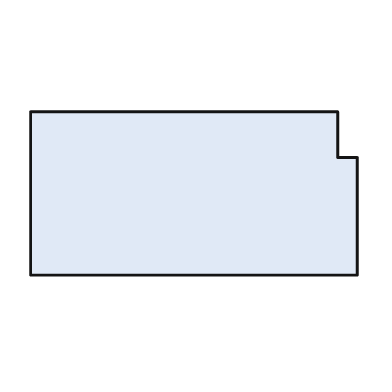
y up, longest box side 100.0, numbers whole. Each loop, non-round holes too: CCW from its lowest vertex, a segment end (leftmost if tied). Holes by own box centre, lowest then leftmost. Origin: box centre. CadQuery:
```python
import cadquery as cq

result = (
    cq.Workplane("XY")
    .moveTo(-50.0, -25.0)
    .lineTo(50.0, -25.0)
    .lineTo(50.0, 11.0)
    .lineTo(44.0, 11.0)
    .lineTo(44.0, 25.0)
    .lineTo(-50.0, 25.0)
    .close()
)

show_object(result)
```